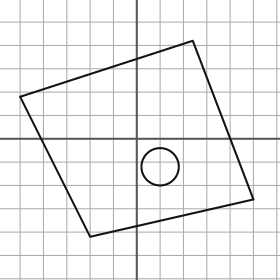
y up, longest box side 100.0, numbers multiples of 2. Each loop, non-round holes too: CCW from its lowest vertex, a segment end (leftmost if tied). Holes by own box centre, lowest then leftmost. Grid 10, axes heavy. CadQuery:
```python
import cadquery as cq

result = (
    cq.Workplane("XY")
    .moveTo(-20.0, -42.0)
    .lineTo(50.0, -26.0)
    .lineTo(24.0, 42.0)
    .lineTo(-50.0, 18.0)
    .close()
    .moveTo(10.0, -12.0)
    .circle(8.0)
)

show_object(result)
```